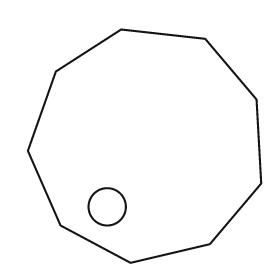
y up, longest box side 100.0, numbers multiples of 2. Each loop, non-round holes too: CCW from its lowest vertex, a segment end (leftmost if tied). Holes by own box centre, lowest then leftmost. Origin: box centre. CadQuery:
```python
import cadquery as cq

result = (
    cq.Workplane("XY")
    .moveTo(-6.0, -50.0)
    .lineTo(28.0, -42.0)
    .lineTo(50.0, -16.0)
    .lineTo(48.0, 20.0)
    .lineTo(26.0, 46.0)
    .lineTo(-10.0, 50.0)
    .lineTo(-38.0, 32.0)
    .lineTo(-50.0, -2.0)
    .lineTo(-36.0, -34.0)
    .close()
    .moveTo(-16.0, -26.0)
    .circle(8.0)
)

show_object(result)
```